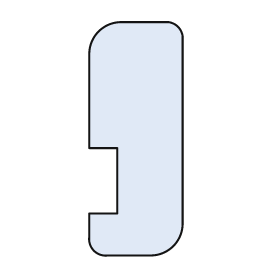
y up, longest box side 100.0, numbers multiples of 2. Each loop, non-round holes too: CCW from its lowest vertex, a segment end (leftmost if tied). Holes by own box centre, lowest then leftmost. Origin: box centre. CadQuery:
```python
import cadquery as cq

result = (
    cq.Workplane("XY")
    .moveTo(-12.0, -50.0)
    .lineTo(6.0, -50.0)
    .threePointArc((16.0, -46.0), (20.0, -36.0))
    .lineTo(20.0, 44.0)
    .threePointArc((18.0, 48.0), (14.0, 50.0))
    .lineTo(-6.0, 50.0)
    .threePointArc((-16.0, 46.0), (-20.0, 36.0))
    .lineTo(-20.0, -4.0)
    .lineTo(-8.0, -4.0)
    .lineTo(-8.0, -32.0)
    .lineTo(-20.0, -32.0)
    .lineTo(-20.0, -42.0)
    .threePointArc((-18.0, -48.0), (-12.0, -50.0))
    .close()
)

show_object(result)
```